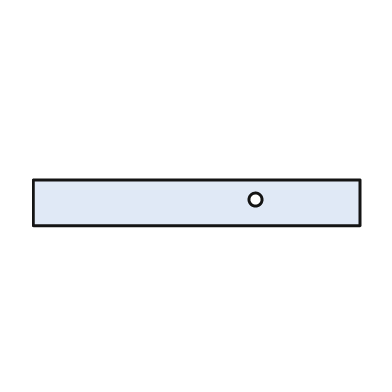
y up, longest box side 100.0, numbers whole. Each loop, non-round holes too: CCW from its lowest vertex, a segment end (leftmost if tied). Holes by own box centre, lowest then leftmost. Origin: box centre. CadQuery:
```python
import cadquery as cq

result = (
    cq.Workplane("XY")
    .moveTo(-50.0, -7.0)
    .lineTo(50.0, -7.0)
    .lineTo(50.0, 7.0)
    .lineTo(-50.0, 7.0)
    .close()
    .moveTo(18.0, 1.0)
    .circle(2.0)
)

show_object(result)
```